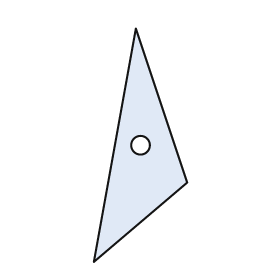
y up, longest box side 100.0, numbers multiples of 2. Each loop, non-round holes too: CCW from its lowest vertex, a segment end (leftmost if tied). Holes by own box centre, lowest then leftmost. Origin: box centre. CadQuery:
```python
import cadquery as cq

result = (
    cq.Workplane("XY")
    .moveTo(-20.0, -50.0)
    .lineTo(20.0, -16.0)
    .lineTo(-2.0, 50.0)
    .close()
    .moveTo(0.0, 0.0)
    .circle(4.0)
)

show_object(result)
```